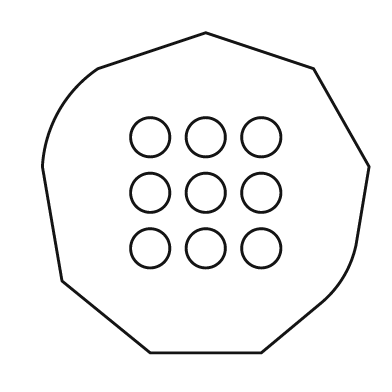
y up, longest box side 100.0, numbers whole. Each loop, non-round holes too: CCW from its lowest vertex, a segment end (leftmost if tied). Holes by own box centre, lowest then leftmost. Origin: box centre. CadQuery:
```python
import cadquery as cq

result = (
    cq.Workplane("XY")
    .moveTo(-17.0, -49.0)
    .lineTo(17.0, -49.0)
    .lineTo(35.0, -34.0)
    .threePointArc((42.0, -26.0), (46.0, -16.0))
    .lineTo(50.0, 8.0)
    .lineTo(33.0, 38.0)
    .lineTo(0.0, 49.0)
    .lineTo(-33.0, 38.0)
    .threePointArc((-45.0, 25.0), (-50.0, 8.0))
    .lineTo(-44.0, -27.0)
    .close()
    .moveTo(-17.0, -17.0)
    .circle(6.0)
    .moveTo(0.0, -17.0)
    .circle(6.0)
    .moveTo(17.0, -17.0)
    .circle(6.0)
    .moveTo(-17.0, 0.0)
    .circle(6.0)
    .moveTo(0.0, 0.0)
    .circle(6.0)
    .moveTo(17.0, 0.0)
    .circle(6.0)
    .moveTo(-17.0, 17.0)
    .circle(6.0)
    .moveTo(0.0, 17.0)
    .circle(6.0)
    .moveTo(17.0, 17.0)
    .circle(6.0)
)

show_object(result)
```